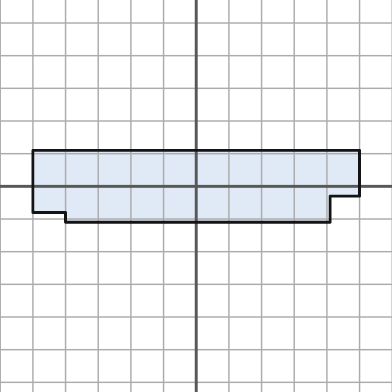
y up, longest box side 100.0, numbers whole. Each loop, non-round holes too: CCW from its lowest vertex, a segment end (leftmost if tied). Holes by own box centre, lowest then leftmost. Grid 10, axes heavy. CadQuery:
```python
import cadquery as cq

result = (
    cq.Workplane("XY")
    .moveTo(-40.0, -11.0)
    .lineTo(41.0, -11.0)
    .lineTo(41.0, -3.0)
    .lineTo(50.0, -3.0)
    .lineTo(50.0, 11.0)
    .lineTo(-50.0, 11.0)
    .lineTo(-50.0, -8.0)
    .lineTo(-40.0, -8.0)
    .close()
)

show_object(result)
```